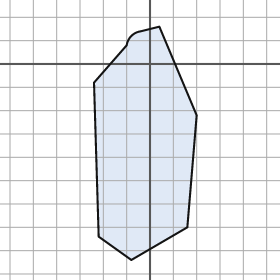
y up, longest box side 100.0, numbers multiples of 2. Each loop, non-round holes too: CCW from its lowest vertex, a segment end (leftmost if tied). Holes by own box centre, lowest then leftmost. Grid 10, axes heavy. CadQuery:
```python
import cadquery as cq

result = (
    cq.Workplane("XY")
    .moveTo(-8.0, -84.0)
    .lineTo(16.0, -70.0)
    .lineTo(20.0, -22.0)
    .lineTo(4.0, 16.0)
    .lineTo(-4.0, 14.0)
    .threePointArc((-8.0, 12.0), (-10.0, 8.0))
    .lineTo(-24.0, -8.0)
    .lineTo(-22.0, -74.0)
    .close()
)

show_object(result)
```